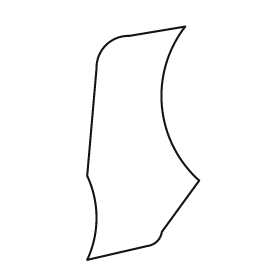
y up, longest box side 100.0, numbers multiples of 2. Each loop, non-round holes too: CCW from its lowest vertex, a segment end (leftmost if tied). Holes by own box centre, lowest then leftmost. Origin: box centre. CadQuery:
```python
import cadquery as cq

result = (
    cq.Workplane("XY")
    .moveTo(-24.0, -50.0)
    .lineTo(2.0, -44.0)
    .threePointArc((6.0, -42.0), (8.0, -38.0))
    .lineTo(24.0, -16.0)
    .threePointArc((8.0, 16.0), (18.0, 50.0))
    .lineTo(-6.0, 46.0)
    .threePointArc((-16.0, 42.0), (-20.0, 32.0))
    .lineTo(-24.0, -14.0)
    .threePointArc((-20.0, -32.0), (-24.0, -50.0))
    .close()
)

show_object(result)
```